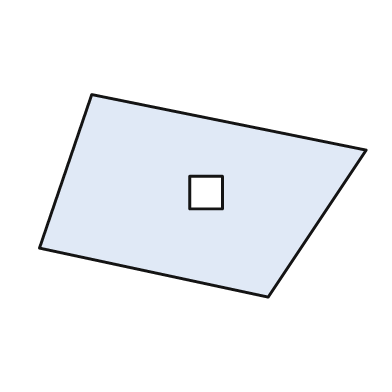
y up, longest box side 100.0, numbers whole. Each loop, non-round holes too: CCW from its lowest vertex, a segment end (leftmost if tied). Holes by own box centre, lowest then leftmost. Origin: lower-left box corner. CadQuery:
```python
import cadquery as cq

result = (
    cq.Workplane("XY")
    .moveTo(70.0, 0.0)
    .lineTo(100.0, 45.0)
    .lineTo(16.0, 62.0)
    .lineTo(0.0, 15.0)
    .close()
    .moveTo(46.0, 27.0)
    .lineTo(56.0, 27.0)
    .lineTo(56.0, 37.0)
    .lineTo(46.0, 37.0)
    .close()
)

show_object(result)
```